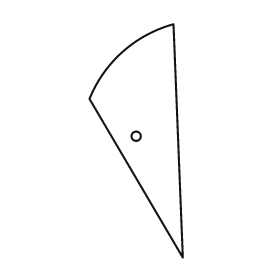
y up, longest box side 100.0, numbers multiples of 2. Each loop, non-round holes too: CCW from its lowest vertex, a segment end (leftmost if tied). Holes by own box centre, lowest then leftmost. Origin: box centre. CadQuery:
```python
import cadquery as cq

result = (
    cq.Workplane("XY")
    .moveTo(20.0, -50.0)
    .lineTo(16.0, 50.0)
    .threePointArc((-6.0, 38.0), (-20.0, 18.0))
    .close()
    .moveTo(0.0, 2.0)
    .circle(2.0)
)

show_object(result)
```